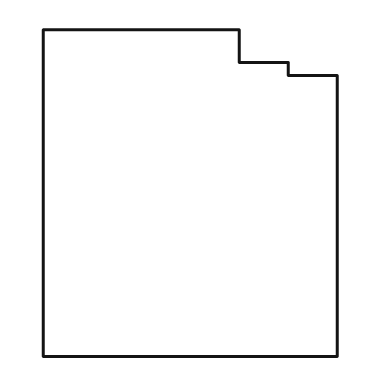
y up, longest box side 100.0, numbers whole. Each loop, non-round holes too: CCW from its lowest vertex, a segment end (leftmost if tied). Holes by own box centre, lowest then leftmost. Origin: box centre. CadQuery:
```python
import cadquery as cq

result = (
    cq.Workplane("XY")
    .moveTo(-45.0, -50.0)
    .lineTo(45.0, -50.0)
    .lineTo(45.0, 36.0)
    .lineTo(30.0, 36.0)
    .lineTo(30.0, 40.0)
    .lineTo(15.0, 40.0)
    .lineTo(15.0, 50.0)
    .lineTo(-45.0, 50.0)
    .close()
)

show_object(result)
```